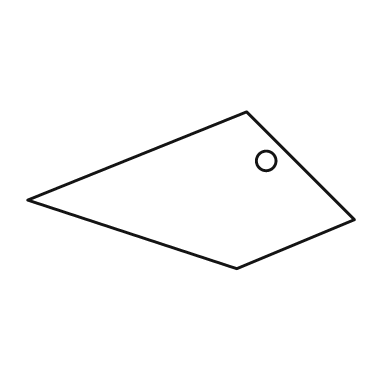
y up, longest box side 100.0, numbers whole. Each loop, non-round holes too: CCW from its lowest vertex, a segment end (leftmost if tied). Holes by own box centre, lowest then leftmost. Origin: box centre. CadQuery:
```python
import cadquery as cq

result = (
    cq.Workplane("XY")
    .moveTo(14.0, -24.0)
    .lineTo(50.0, -9.0)
    .lineTo(17.0, 24.0)
    .lineTo(-50.0, -3.0)
    .close()
    .moveTo(23.0, 9.0)
    .circle(3.0)
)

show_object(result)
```